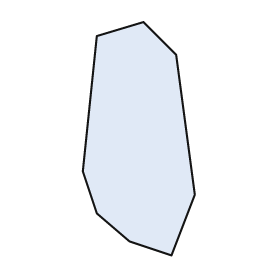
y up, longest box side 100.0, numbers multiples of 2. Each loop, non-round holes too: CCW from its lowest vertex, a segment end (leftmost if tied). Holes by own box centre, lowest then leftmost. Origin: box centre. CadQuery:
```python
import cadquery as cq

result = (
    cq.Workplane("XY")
    .moveTo(14.0, -50.0)
    .lineTo(24.0, -24.0)
    .lineTo(16.0, 36.0)
    .lineTo(2.0, 50.0)
    .lineTo(-18.0, 44.0)
    .lineTo(-24.0, -14.0)
    .lineTo(-18.0, -32.0)
    .lineTo(-4.0, -44.0)
    .close()
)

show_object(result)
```